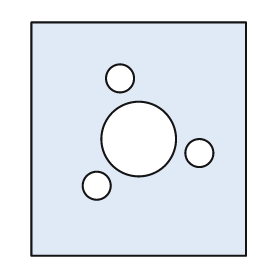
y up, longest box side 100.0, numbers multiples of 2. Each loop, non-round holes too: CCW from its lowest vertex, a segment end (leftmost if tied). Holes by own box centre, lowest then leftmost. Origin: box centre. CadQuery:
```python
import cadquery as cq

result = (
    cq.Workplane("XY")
    .moveTo(-46.0, -50.0)
    .lineTo(46.0, -50.0)
    .lineTo(46.0, 50.0)
    .lineTo(-46.0, 50.0)
    .close()
    .moveTo(-18.0, -20.0)
    .circle(6.0)
    .moveTo(26.0, -6.0)
    .circle(6.0)
    .moveTo(0.0, 0.0)
    .circle(16.0)
    .moveTo(-8.0, 26.0)
    .circle(6.0)
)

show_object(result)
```